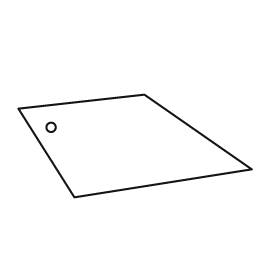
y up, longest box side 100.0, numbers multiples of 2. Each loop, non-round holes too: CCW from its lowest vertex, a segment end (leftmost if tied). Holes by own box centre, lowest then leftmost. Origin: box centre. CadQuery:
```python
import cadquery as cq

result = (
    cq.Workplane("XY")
    .moveTo(-26.0, -22.0)
    .lineTo(50.0, -10.0)
    .lineTo(4.0, 22.0)
    .lineTo(-50.0, 16.0)
    .close()
    .moveTo(-36.0, 8.0)
    .circle(2.0)
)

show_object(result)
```